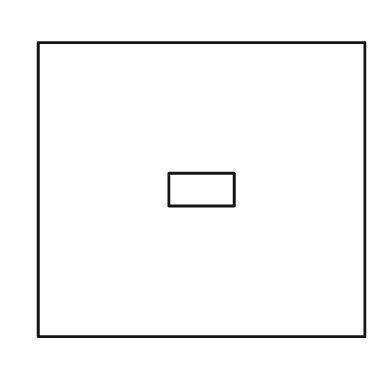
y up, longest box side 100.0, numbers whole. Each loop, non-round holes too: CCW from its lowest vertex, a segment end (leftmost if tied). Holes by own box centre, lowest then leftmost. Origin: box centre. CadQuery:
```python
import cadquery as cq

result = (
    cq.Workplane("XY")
    .moveTo(-50.0, -45.0)
    .lineTo(50.0, -45.0)
    .lineTo(50.0, 45.0)
    .lineTo(-50.0, 45.0)
    .close()
    .moveTo(-10.0, -5.0)
    .lineTo(10.0, -5.0)
    .lineTo(10.0, 5.0)
    .lineTo(-10.0, 5.0)
    .close()
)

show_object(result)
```